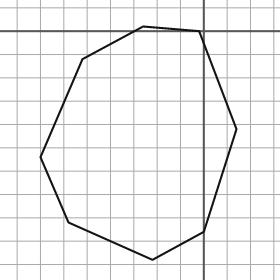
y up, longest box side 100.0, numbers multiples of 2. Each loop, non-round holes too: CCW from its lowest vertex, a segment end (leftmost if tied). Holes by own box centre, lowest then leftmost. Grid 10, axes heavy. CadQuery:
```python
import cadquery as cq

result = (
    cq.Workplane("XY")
    .moveTo(-22.0, -98.0)
    .lineTo(0.0, -86.0)
    .lineTo(14.0, -42.0)
    .lineTo(-2.0, 0.0)
    .lineTo(-26.0, 2.0)
    .lineTo(-52.0, -12.0)
    .lineTo(-70.0, -54.0)
    .lineTo(-58.0, -82.0)
    .close()
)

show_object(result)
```